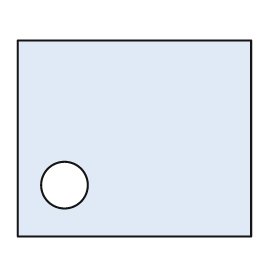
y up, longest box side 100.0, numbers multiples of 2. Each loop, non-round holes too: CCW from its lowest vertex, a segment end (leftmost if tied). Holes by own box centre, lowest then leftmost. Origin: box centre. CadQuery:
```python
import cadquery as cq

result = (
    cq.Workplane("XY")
    .moveTo(-50.0, -42.0)
    .lineTo(50.0, -42.0)
    .lineTo(50.0, 42.0)
    .lineTo(-50.0, 42.0)
    .close()
    .moveTo(-30.0, -20.0)
    .circle(10.0)
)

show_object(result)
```